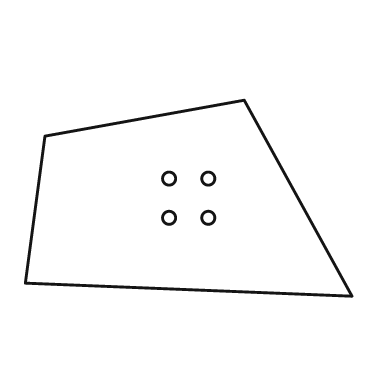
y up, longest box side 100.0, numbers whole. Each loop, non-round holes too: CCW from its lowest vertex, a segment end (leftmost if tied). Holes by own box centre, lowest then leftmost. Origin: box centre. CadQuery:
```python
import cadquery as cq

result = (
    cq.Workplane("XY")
    .moveTo(50.0, -30.0)
    .lineTo(17.0, 30.0)
    .lineTo(-44.0, 19.0)
    .lineTo(-50.0, -26.0)
    .close()
    .moveTo(-6.0, -6.0)
    .circle(2.0)
    .moveTo(6.0, -6.0)
    .circle(2.0)
    .moveTo(-6.0, 6.0)
    .circle(2.0)
    .moveTo(6.0, 6.0)
    .circle(2.0)
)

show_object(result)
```